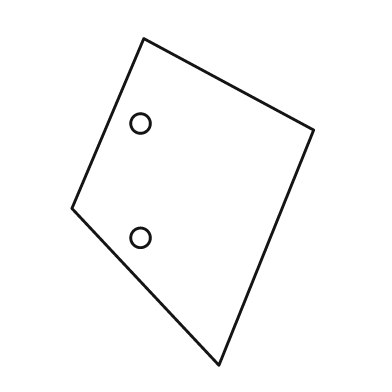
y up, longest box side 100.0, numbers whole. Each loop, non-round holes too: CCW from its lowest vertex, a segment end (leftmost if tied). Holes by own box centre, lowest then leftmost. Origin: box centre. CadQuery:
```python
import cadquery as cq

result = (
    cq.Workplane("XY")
    .moveTo(8.0, -50.0)
    .lineTo(37.0, 22.0)
    .lineTo(-15.0, 50.0)
    .lineTo(-37.0, -2.0)
    .close()
    .moveTo(-16.0, -11.0)
    .circle(3.0)
    .moveTo(-16.0, 24.0)
    .circle(3.0)
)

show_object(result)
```